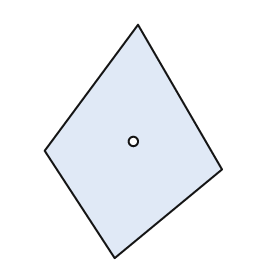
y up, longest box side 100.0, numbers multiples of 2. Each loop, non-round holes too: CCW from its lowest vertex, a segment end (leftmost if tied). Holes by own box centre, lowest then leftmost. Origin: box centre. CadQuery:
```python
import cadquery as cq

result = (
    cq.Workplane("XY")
    .moveTo(-8.0, -50.0)
    .lineTo(38.0, -12.0)
    .lineTo(2.0, 50.0)
    .lineTo(-38.0, -4.0)
    .close()
    .moveTo(0.0, 0.0)
    .circle(2.0)
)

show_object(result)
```